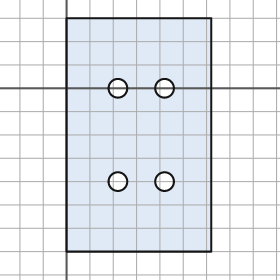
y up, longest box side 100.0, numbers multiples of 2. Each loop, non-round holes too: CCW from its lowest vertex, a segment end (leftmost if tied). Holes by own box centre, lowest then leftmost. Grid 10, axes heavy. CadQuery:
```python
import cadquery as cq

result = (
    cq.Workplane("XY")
    .moveTo(0.0, -70.0)
    .lineTo(62.0, -70.0)
    .lineTo(62.0, 30.0)
    .lineTo(0.0, 30.0)
    .close()
    .moveTo(22.0, -40.0)
    .circle(4.0)
    .moveTo(42.0, -40.0)
    .circle(4.0)
    .moveTo(22.0, 0.0)
    .circle(4.0)
    .moveTo(42.0, 0.0)
    .circle(4.0)
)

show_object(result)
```